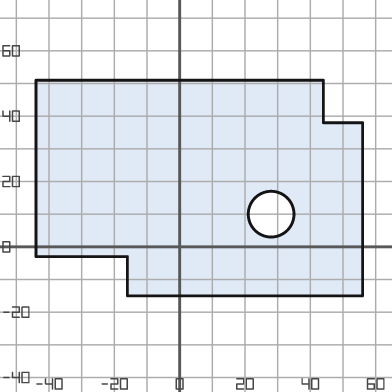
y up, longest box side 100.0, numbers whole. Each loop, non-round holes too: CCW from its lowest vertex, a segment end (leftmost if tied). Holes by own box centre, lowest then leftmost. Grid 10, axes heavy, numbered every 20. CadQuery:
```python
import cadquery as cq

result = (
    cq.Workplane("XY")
    .moveTo(-16.0, -15.0)
    .lineTo(56.0, -15.0)
    .lineTo(56.0, 38.0)
    .lineTo(44.0, 38.0)
    .lineTo(44.0, 51.0)
    .lineTo(-44.0, 51.0)
    .lineTo(-44.0, -3.0)
    .lineTo(-16.0, -3.0)
    .close()
    .moveTo(28.0, 10.0)
    .circle(7.0)
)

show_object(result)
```